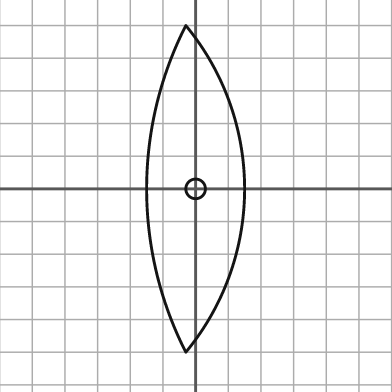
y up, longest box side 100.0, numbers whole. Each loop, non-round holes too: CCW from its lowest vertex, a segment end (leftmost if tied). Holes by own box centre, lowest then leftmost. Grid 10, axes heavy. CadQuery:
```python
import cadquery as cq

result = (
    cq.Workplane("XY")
    .moveTo(-3.0, -50.0)
    .threePointArc((15.0, 0.0), (-3.0, 50.0))
    .threePointArc((-15.0, 0.0), (-3.0, -50.0))
    .close()
    .moveTo(0.0, 0.0)
    .circle(3.0)
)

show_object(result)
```